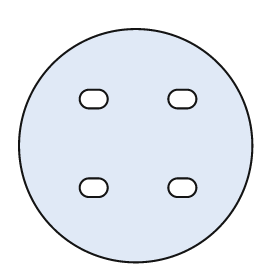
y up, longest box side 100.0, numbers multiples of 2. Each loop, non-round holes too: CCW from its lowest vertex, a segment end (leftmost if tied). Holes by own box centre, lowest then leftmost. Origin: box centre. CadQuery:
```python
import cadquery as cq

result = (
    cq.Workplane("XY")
    .moveTo(0.0, 0.0)
    .circle(50.0)
    .moveTo(-20.0, -22.0)
    .lineTo(-16.0, -22.0)
    .threePointArc((-12.0, -18.0), (-16.0, -14.0))
    .lineTo(-20.0, -14.0)
    .threePointArc((-24.0, -18.0), (-20.0, -22.0))
    .close()
    .moveTo(18.0, -22.0)
    .lineTo(22.0, -22.0)
    .threePointArc((26.0, -18.0), (22.0, -14.0))
    .lineTo(18.0, -14.0)
    .threePointArc((14.0, -18.0), (18.0, -22.0))
    .close()
    .moveTo(-20.0, 16.0)
    .lineTo(-16.0, 16.0)
    .threePointArc((-12.0, 20.0), (-16.0, 24.0))
    .lineTo(-20.0, 24.0)
    .threePointArc((-24.0, 20.0), (-20.0, 16.0))
    .close()
    .moveTo(18.0, 16.0)
    .lineTo(22.0, 16.0)
    .threePointArc((26.0, 20.0), (22.0, 24.0))
    .lineTo(18.0, 24.0)
    .threePointArc((14.0, 20.0), (18.0, 16.0))
    .close()
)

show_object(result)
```